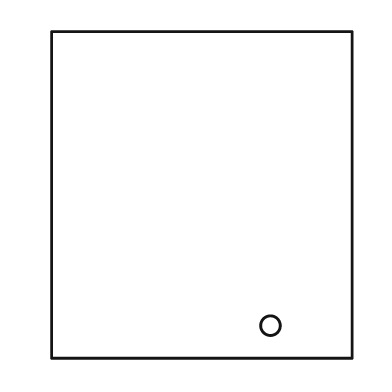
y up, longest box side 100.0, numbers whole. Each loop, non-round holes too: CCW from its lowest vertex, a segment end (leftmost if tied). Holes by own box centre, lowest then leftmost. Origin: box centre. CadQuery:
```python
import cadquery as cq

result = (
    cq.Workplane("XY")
    .moveTo(-46.0, -50.0)
    .lineTo(46.0, -50.0)
    .lineTo(46.0, 50.0)
    .lineTo(-46.0, 50.0)
    .close()
    .moveTo(21.0, -40.0)
    .circle(3.0)
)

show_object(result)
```